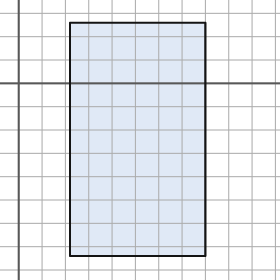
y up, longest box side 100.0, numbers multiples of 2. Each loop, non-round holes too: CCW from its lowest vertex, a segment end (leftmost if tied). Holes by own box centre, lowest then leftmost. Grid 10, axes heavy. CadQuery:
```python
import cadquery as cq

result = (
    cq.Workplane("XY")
    .moveTo(22.0, -74.0)
    .lineTo(80.0, -74.0)
    .lineTo(80.0, 26.0)
    .lineTo(22.0, 26.0)
    .close()
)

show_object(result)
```